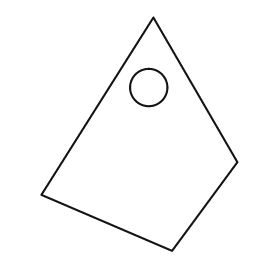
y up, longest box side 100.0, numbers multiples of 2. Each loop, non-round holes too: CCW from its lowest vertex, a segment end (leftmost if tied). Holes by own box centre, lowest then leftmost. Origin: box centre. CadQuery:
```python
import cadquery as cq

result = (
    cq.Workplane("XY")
    .moveTo(14.0, -50.0)
    .lineTo(42.0, -12.0)
    .lineTo(6.0, 50.0)
    .lineTo(-42.0, -26.0)
    .close()
    .moveTo(4.0, 20.0)
    .circle(8.0)
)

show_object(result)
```